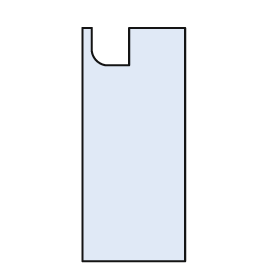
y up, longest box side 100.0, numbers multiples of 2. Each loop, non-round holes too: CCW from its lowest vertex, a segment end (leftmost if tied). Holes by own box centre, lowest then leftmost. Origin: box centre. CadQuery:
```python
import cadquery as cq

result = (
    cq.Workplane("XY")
    .moveTo(-22.0, -50.0)
    .lineTo(22.0, -50.0)
    .lineTo(22.0, 50.0)
    .lineTo(-2.0, 50.0)
    .lineTo(-2.0, 34.0)
    .lineTo(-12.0, 34.0)
    .threePointArc((-16.0, 36.0), (-18.0, 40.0))
    .lineTo(-18.0, 50.0)
    .lineTo(-22.0, 50.0)
    .close()
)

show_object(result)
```